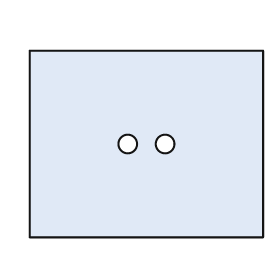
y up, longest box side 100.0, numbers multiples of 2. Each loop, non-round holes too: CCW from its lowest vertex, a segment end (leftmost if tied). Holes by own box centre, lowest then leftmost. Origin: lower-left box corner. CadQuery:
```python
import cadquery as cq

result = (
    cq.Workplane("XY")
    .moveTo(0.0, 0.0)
    .lineTo(100.0, 0.0)
    .lineTo(100.0, 80.0)
    .lineTo(0.0, 80.0)
    .close()
    .moveTo(42.0, 40.0)
    .circle(4.0)
    .moveTo(58.0, 40.0)
    .circle(4.0)
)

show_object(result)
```